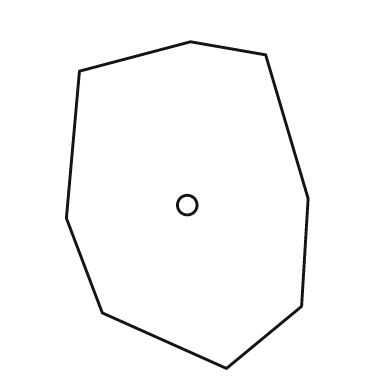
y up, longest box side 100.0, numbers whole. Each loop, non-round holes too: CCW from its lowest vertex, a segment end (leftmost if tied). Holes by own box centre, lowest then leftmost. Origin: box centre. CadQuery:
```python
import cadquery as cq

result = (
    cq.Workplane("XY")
    .moveTo(12.0, -50.0)
    .lineTo(35.0, -31.0)
    .lineTo(37.0, 2.0)
    .lineTo(24.0, 46.0)
    .lineTo(1.0, 50.0)
    .lineTo(-33.0, 41.0)
    .lineTo(-37.0, -4.0)
    .lineTo(-26.0, -33.0)
    .close()
    .moveTo(0.0, 0.0)
    .circle(3.0)
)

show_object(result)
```